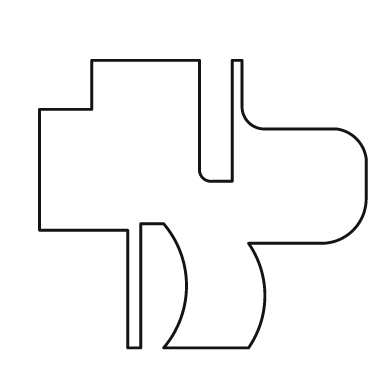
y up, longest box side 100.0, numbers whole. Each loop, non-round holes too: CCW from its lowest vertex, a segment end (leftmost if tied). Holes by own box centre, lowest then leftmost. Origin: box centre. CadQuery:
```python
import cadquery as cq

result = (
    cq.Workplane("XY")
    .moveTo(-23.0, -44.0)
    .lineTo(-19.0, -44.0)
    .lineTo(-19.0, -6.0)
    .lineTo(-12.0, -6.0)
    .threePointArc((-5.0, -25.0), (-12.0, -44.0))
    .lineTo(14.0, -44.0)
    .threePointArc((19.0, -28.0), (14.0, -12.0))
    .lineTo(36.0, -12.0)
    .threePointArc((46.0, -8.0), (50.0, 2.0))
    .lineTo(50.0, 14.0)
    .threePointArc((47.0, 20.0), (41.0, 23.0))
    .lineTo(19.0, 23.0)
    .threePointArc((14.0, 25.0), (12.0, 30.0))
    .lineTo(12.0, 44.0)
    .lineTo(9.0, 44.0)
    .lineTo(9.0, 7.0)
    .lineTo(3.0, 7.0)
    .threePointArc((0.0, 8.0), (-1.0, 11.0))
    .lineTo(-1.0, 44.0)
    .lineTo(-34.0, 44.0)
    .lineTo(-34.0, 29.0)
    .lineTo(-50.0, 29.0)
    .lineTo(-50.0, -8.0)
    .lineTo(-23.0, -8.0)
    .close()
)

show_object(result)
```